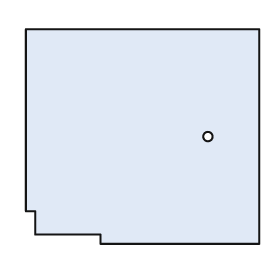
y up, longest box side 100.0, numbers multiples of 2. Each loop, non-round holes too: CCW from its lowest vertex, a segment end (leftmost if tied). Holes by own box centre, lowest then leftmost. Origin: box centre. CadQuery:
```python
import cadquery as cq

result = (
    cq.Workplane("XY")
    .moveTo(-18.0, -46.0)
    .lineTo(50.0, -46.0)
    .lineTo(50.0, 46.0)
    .lineTo(-50.0, 46.0)
    .lineTo(-50.0, -32.0)
    .lineTo(-46.0, -32.0)
    .lineTo(-46.0, -42.0)
    .lineTo(-18.0, -42.0)
    .close()
    .moveTo(28.0, 0.0)
    .circle(2.0)
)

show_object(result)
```